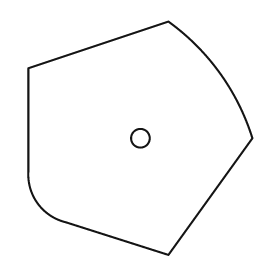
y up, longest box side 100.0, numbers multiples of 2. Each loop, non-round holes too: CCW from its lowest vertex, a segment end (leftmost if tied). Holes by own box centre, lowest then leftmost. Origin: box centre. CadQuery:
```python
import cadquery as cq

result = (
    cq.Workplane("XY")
    .moveTo(12.0, -50.0)
    .lineTo(48.0, 0.0)
    .threePointArc((34.0, 28.0), (12.0, 50.0))
    .lineTo(-48.0, 30.0)
    .lineTo(-48.0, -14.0)
    .threePointArc((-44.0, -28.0), (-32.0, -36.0))
    .close()
    .moveTo(0.0, 0.0)
    .circle(4.0)
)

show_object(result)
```